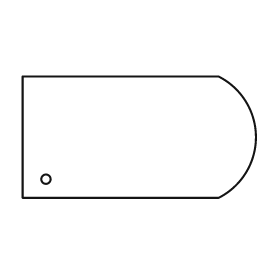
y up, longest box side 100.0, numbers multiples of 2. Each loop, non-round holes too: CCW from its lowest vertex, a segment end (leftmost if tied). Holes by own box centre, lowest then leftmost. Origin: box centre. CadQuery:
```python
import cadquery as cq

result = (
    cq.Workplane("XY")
    .moveTo(-50.0, -26.0)
    .lineTo(34.0, -26.0)
    .threePointArc((50.0, 0.0), (34.0, 26.0))
    .lineTo(-50.0, 26.0)
    .close()
    .moveTo(-40.0, -18.0)
    .circle(2.0)
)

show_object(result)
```